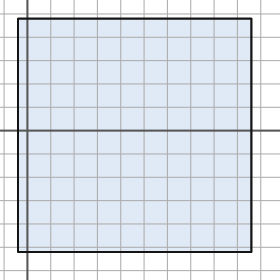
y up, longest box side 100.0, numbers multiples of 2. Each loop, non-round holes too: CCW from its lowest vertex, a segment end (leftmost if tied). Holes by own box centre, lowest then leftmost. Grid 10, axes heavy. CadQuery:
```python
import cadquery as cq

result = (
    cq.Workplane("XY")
    .moveTo(-4.0, -52.0)
    .lineTo(96.0, -52.0)
    .lineTo(96.0, 48.0)
    .lineTo(-4.0, 48.0)
    .close()
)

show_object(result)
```